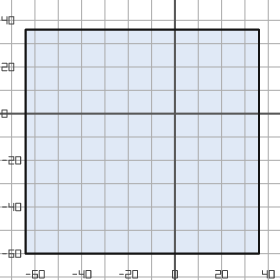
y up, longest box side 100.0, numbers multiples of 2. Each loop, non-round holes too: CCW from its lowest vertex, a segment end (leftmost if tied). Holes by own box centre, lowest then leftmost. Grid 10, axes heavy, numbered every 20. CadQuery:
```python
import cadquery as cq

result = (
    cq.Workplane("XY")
    .moveTo(-64.0, -60.0)
    .lineTo(36.0, -60.0)
    .lineTo(36.0, 36.0)
    .lineTo(-64.0, 36.0)
    .close()
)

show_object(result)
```